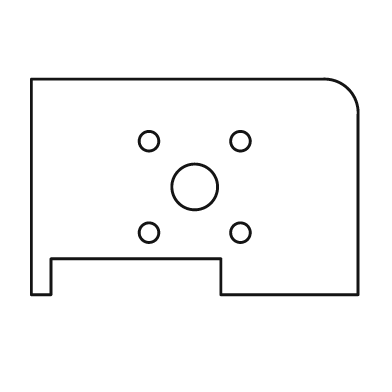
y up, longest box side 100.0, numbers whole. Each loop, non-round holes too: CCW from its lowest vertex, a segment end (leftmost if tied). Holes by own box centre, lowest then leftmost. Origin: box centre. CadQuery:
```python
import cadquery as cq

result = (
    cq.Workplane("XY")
    .moveTo(-50.0, -33.0)
    .lineTo(-44.0, -33.0)
    .lineTo(-44.0, -22.0)
    .lineTo(8.0, -22.0)
    .lineTo(8.0, -33.0)
    .lineTo(50.0, -33.0)
    .lineTo(50.0, 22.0)
    .threePointArc((47.0, 30.0), (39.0, 33.0))
    .lineTo(-50.0, 33.0)
    .close()
    .moveTo(-14.0, -14.0)
    .circle(3.0)
    .moveTo(14.0, -14.0)
    .circle(3.0)
    .moveTo(0.0, 0.0)
    .circle(7.0)
    .moveTo(-14.0, 14.0)
    .circle(3.0)
    .moveTo(14.0, 14.0)
    .circle(3.0)
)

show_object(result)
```